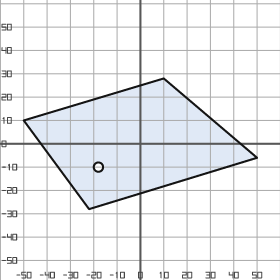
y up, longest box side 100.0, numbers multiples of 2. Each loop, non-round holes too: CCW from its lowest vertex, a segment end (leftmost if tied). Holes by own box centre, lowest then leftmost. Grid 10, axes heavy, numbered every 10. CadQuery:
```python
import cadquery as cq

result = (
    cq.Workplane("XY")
    .moveTo(-22.0, -28.0)
    .lineTo(50.0, -6.0)
    .lineTo(10.0, 28.0)
    .lineTo(-50.0, 10.0)
    .close()
    .moveTo(-18.0, -10.0)
    .circle(2.0)
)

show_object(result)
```